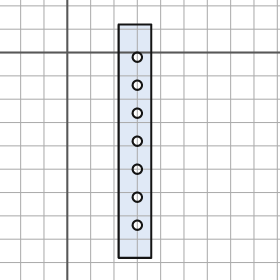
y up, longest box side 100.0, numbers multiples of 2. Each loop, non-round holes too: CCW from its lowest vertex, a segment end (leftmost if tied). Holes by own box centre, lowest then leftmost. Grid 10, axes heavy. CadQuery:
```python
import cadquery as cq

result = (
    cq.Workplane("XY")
    .moveTo(22.0, -88.0)
    .lineTo(36.0, -88.0)
    .lineTo(36.0, 12.0)
    .lineTo(22.0, 12.0)
    .close()
    .moveTo(30.0, -74.0)
    .circle(2.0)
    .moveTo(30.0, -62.0)
    .circle(2.0)
    .moveTo(30.0, -50.0)
    .circle(2.0)
    .moveTo(30.0, -38.0)
    .circle(2.0)
    .moveTo(30.0, -26.0)
    .circle(2.0)
    .moveTo(30.0, -14.0)
    .circle(2.0)
    .moveTo(30.0, -2.0)
    .circle(2.0)
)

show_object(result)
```